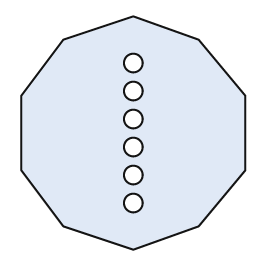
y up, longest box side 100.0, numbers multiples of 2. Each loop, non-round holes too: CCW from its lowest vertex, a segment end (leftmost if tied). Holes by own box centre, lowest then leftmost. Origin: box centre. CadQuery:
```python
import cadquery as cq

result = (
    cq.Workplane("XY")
    .moveTo(0.0, -50.0)
    .lineTo(28.0, -40.0)
    .lineTo(48.0, -16.0)
    .lineTo(48.0, 16.0)
    .lineTo(28.0, 40.0)
    .lineTo(0.0, 50.0)
    .lineTo(-30.0, 40.0)
    .lineTo(-48.0, 16.0)
    .lineTo(-48.0, -16.0)
    .lineTo(-30.0, -40.0)
    .close()
    .moveTo(0.0, -30.0)
    .circle(4.0)
    .moveTo(0.0, -18.0)
    .circle(4.0)
    .moveTo(0.0, -6.0)
    .circle(4.0)
    .moveTo(0.0, 6.0)
    .circle(4.0)
    .moveTo(0.0, 18.0)
    .circle(4.0)
    .moveTo(0.0, 30.0)
    .circle(4.0)
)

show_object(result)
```